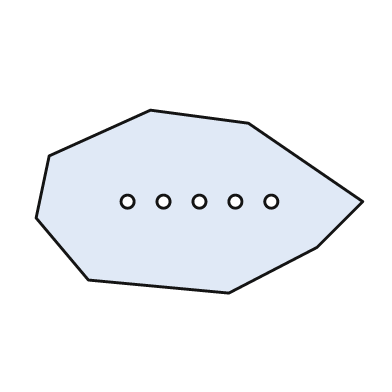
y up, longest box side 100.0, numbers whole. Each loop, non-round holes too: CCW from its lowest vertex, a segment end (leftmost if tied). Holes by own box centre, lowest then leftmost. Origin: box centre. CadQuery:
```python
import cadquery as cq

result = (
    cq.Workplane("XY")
    .moveTo(9.0, -28.0)
    .lineTo(36.0, -14.0)
    .lineTo(50.0, 0.0)
    .lineTo(15.0, 24.0)
    .lineTo(-15.0, 28.0)
    .lineTo(-46.0, 14.0)
    .lineTo(-50.0, -5.0)
    .lineTo(-34.0, -24.0)
    .close()
    .moveTo(-22.0, 0.0)
    .circle(2.0)
    .moveTo(-11.0, 0.0)
    .circle(2.0)
    .moveTo(0.0, 0.0)
    .circle(2.0)
    .moveTo(11.0, 0.0)
    .circle(2.0)
    .moveTo(22.0, 0.0)
    .circle(2.0)
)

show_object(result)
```